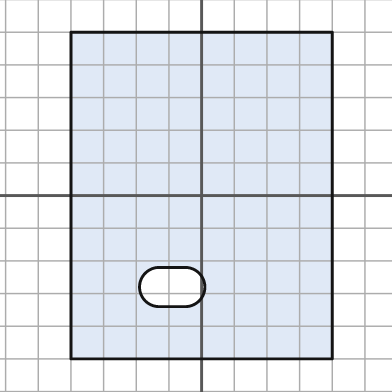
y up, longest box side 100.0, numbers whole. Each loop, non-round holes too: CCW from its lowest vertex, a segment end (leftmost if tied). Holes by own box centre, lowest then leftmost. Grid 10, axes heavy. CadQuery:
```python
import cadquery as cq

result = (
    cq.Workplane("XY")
    .moveTo(-40.0, -50.0)
    .lineTo(40.0, -50.0)
    .lineTo(40.0, 50.0)
    .lineTo(-40.0, 50.0)
    .close()
    .moveTo(-13.0, -34.0)
    .lineTo(-5.0, -34.0)
    .threePointArc((1.0, -28.0), (-5.0, -22.0))
    .lineTo(-13.0, -22.0)
    .threePointArc((-19.0, -28.0), (-13.0, -34.0))
    .close()
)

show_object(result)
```